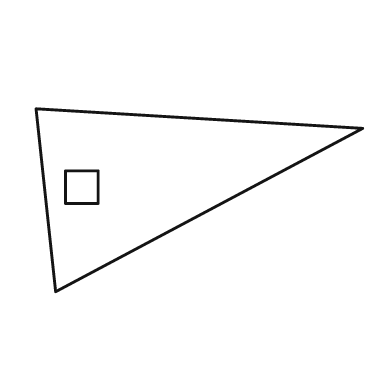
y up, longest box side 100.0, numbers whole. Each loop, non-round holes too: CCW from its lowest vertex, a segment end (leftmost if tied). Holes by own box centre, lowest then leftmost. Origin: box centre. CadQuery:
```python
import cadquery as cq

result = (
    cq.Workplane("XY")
    .moveTo(-44.0, -28.0)
    .lineTo(50.0, 22.0)
    .lineTo(-50.0, 28.0)
    .close()
    .moveTo(-41.0, -1.0)
    .lineTo(-31.0, -1.0)
    .lineTo(-31.0, 9.0)
    .lineTo(-41.0, 9.0)
    .close()
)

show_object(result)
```